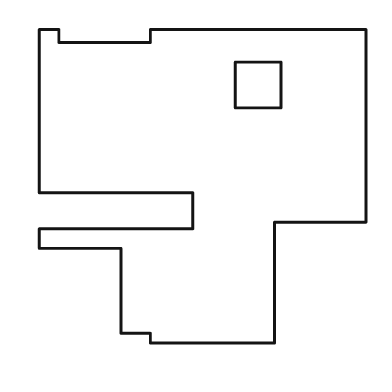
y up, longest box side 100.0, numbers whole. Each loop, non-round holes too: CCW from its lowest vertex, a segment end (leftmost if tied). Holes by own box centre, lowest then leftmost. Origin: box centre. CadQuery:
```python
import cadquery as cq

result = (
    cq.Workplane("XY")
    .moveTo(-16.0, -48.0)
    .lineTo(22.0, -48.0)
    .lineTo(22.0, -11.0)
    .lineTo(50.0, -11.0)
    .lineTo(50.0, 48.0)
    .lineTo(-16.0, 48.0)
    .lineTo(-16.0, 44.0)
    .lineTo(-44.0, 44.0)
    .lineTo(-44.0, 48.0)
    .lineTo(-50.0, 48.0)
    .lineTo(-50.0, -2.0)
    .lineTo(-3.0, -2.0)
    .lineTo(-3.0, -13.0)
    .lineTo(-50.0, -13.0)
    .lineTo(-50.0, -19.0)
    .lineTo(-25.0, -19.0)
    .lineTo(-25.0, -45.0)
    .lineTo(-16.0, -45.0)
    .close()
    .moveTo(10.0, 24.0)
    .lineTo(24.0, 24.0)
    .lineTo(24.0, 38.0)
    .lineTo(10.0, 38.0)
    .close()
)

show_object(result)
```